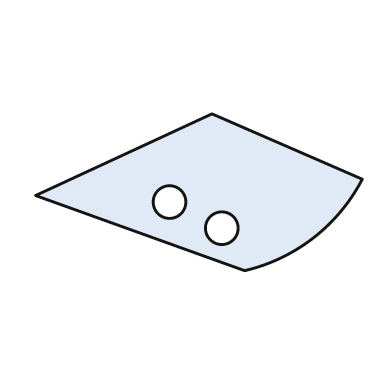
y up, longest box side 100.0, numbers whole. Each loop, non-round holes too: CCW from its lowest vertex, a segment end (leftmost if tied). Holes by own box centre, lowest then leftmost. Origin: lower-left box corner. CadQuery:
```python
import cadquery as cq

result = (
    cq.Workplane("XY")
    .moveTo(64.0, 0.0)
    .threePointArc((85.0, 10.0), (100.0, 28.0))
    .lineTo(54.0, 48.0)
    .lineTo(0.0, 23.0)
    .close()
    .moveTo(57.0, 13.0)
    .circle(5.0)
    .moveTo(41.0, 21.0)
    .circle(5.0)
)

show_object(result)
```